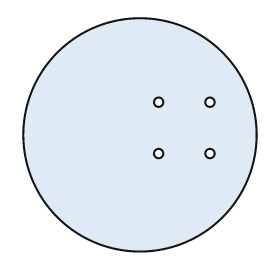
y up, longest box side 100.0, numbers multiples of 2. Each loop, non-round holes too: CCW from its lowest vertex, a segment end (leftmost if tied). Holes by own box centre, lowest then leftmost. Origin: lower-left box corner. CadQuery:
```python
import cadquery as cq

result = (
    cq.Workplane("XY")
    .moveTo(50.0, 50.0)
    .circle(50.0)
    .moveTo(58.0, 42.0)
    .circle(2.0)
    .moveTo(80.0, 42.0)
    .circle(2.0)
    .moveTo(58.0, 64.0)
    .circle(2.0)
    .moveTo(80.0, 64.0)
    .circle(2.0)
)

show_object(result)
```